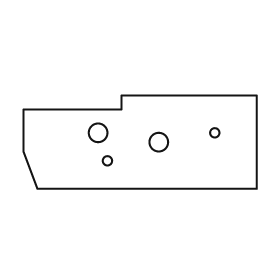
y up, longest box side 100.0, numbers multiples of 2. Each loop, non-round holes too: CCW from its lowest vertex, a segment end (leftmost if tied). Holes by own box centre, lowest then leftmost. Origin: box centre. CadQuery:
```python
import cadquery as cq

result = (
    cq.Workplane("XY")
    .moveTo(-44.0, -20.0)
    .lineTo(50.0, -20.0)
    .lineTo(50.0, 20.0)
    .lineTo(-8.0, 20.0)
    .lineTo(-8.0, 14.0)
    .lineTo(-50.0, 14.0)
    .lineTo(-50.0, -4.0)
    .close()
    .moveTo(-14.0, -8.0)
    .circle(2.0)
    .moveTo(8.0, 0.0)
    .circle(4.0)
    .moveTo(-18.0, 4.0)
    .circle(4.0)
    .moveTo(32.0, 4.0)
    .circle(2.0)
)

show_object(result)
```